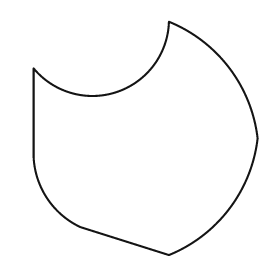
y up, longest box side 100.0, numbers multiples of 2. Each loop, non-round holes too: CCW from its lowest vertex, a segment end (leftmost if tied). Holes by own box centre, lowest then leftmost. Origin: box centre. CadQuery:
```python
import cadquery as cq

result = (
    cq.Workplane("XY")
    .moveTo(10.0, -50.0)
    .threePointArc((36.0, -30.0), (48.0, 0.0))
    .threePointArc((36.0, 30.0), (10.0, 50.0))
    .threePointArc((-12.0, 20.0), (-48.0, 30.0))
    .lineTo(-48.0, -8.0)
    .threePointArc((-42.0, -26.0), (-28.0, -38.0))
    .close()
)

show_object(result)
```